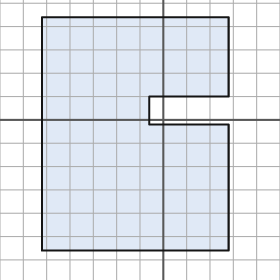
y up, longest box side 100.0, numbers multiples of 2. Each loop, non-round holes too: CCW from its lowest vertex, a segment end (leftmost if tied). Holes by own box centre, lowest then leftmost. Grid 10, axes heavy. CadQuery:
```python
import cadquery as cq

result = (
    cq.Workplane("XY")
    .moveTo(-52.0, -56.0)
    .lineTo(28.0, -56.0)
    .lineTo(28.0, -2.0)
    .lineTo(-6.0, -2.0)
    .lineTo(-6.0, 10.0)
    .lineTo(28.0, 10.0)
    .lineTo(28.0, 44.0)
    .lineTo(-52.0, 44.0)
    .close()
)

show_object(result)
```